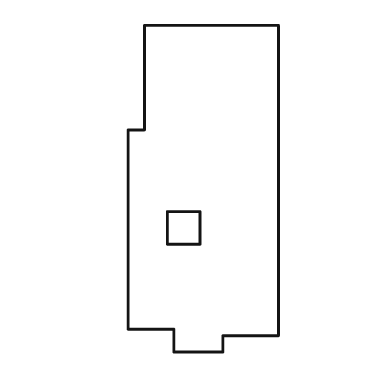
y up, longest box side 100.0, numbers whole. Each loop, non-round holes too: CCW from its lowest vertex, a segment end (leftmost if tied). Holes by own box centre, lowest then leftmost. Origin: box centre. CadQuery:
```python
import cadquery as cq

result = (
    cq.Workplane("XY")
    .moveTo(-9.0, -50.0)
    .lineTo(6.0, -50.0)
    .lineTo(6.0, -45.0)
    .lineTo(23.0, -45.0)
    .lineTo(23.0, 50.0)
    .lineTo(-18.0, 50.0)
    .lineTo(-18.0, 18.0)
    .lineTo(-23.0, 18.0)
    .lineTo(-23.0, -43.0)
    .lineTo(-9.0, -43.0)
    .close()
    .moveTo(-11.0, -17.0)
    .lineTo(-1.0, -17.0)
    .lineTo(-1.0, -7.0)
    .lineTo(-11.0, -7.0)
    .close()
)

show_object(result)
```